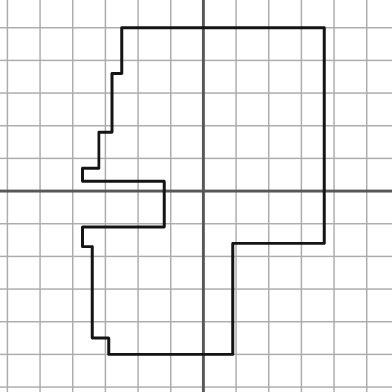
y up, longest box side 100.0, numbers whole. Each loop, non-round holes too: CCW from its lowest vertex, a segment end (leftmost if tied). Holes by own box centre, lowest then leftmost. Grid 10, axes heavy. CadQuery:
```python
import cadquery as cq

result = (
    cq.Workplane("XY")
    .moveTo(-29.0, -50.0)
    .lineTo(9.0, -50.0)
    .lineTo(9.0, -16.0)
    .lineTo(37.0, -16.0)
    .lineTo(37.0, 50.0)
    .lineTo(-25.0, 50.0)
    .lineTo(-25.0, 36.0)
    .lineTo(-28.0, 36.0)
    .lineTo(-28.0, 18.0)
    .lineTo(-32.0, 18.0)
    .lineTo(-32.0, 7.0)
    .lineTo(-37.0, 7.0)
    .lineTo(-37.0, 3.0)
    .lineTo(-12.0, 3.0)
    .lineTo(-12.0, -11.0)
    .lineTo(-37.0, -11.0)
    .lineTo(-37.0, -17.0)
    .lineTo(-34.0, -17.0)
    .lineTo(-34.0, -45.0)
    .lineTo(-29.0, -45.0)
    .close()
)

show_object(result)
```